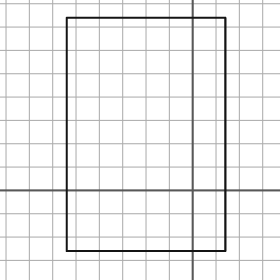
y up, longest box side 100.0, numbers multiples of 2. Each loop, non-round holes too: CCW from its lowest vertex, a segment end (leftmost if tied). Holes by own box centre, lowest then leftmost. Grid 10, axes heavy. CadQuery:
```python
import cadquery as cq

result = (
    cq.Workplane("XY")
    .moveTo(-54.0, -26.0)
    .lineTo(14.0, -26.0)
    .lineTo(14.0, 74.0)
    .lineTo(-54.0, 74.0)
    .close()
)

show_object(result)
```